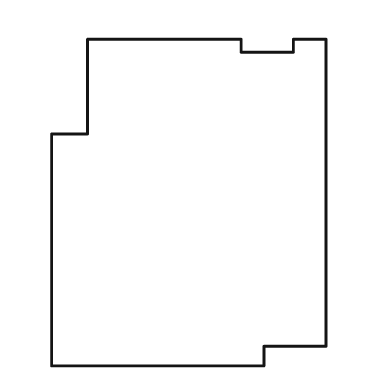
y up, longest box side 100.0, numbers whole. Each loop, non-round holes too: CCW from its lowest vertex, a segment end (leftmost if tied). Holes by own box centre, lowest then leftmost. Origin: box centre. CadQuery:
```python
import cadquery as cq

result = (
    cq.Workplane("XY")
    .moveTo(-42.0, -50.0)
    .lineTo(23.0, -50.0)
    .lineTo(23.0, -44.0)
    .lineTo(42.0, -44.0)
    .lineTo(42.0, 50.0)
    .lineTo(32.0, 50.0)
    .lineTo(32.0, 46.0)
    .lineTo(16.0, 46.0)
    .lineTo(16.0, 50.0)
    .lineTo(-31.0, 50.0)
    .lineTo(-31.0, 21.0)
    .lineTo(-42.0, 21.0)
    .close()
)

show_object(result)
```